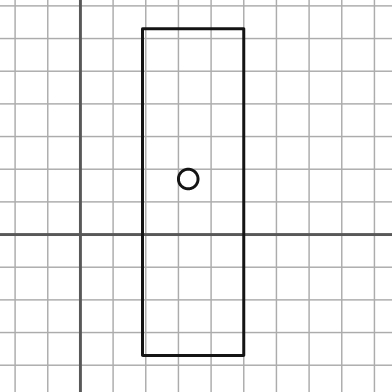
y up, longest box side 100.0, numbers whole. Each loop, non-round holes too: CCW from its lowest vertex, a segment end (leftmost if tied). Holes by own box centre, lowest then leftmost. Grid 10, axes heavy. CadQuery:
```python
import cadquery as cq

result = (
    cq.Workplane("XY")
    .moveTo(19.0, -37.0)
    .lineTo(50.0, -37.0)
    .lineTo(50.0, 63.0)
    .lineTo(19.0, 63.0)
    .close()
    .moveTo(33.0, 17.0)
    .circle(3.0)
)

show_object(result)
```